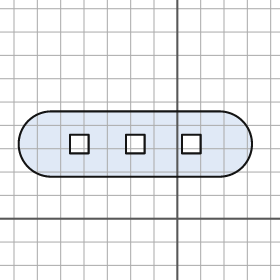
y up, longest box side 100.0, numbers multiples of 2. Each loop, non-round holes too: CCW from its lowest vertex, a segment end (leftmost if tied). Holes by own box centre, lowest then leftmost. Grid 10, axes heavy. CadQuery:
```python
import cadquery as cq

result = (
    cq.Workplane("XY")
    .moveTo(-54.0, 18.0)
    .lineTo(18.0, 18.0)
    .threePointArc((32.0, 32.0), (18.0, 46.0))
    .lineTo(-54.0, 46.0)
    .threePointArc((-68.0, 32.0), (-54.0, 18.0))
    .close()
    .moveTo(-46.0, 28.0)
    .lineTo(-38.0, 28.0)
    .lineTo(-38.0, 36.0)
    .lineTo(-46.0, 36.0)
    .close()
    .moveTo(-22.0, 28.0)
    .lineTo(-14.0, 28.0)
    .lineTo(-14.0, 36.0)
    .lineTo(-22.0, 36.0)
    .close()
    .moveTo(2.0, 28.0)
    .lineTo(10.0, 28.0)
    .lineTo(10.0, 36.0)
    .lineTo(2.0, 36.0)
    .close()
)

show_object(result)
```